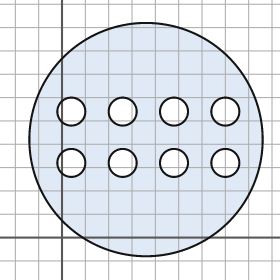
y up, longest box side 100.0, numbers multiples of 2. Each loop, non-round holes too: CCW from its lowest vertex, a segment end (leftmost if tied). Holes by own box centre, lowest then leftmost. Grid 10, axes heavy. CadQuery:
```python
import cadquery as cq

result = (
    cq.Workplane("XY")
    .moveTo(36.0, 42.0)
    .circle(50.0)
    .moveTo(4.0, 32.0)
    .circle(6.0)
    .moveTo(26.0, 32.0)
    .circle(6.0)
    .moveTo(48.0, 32.0)
    .circle(6.0)
    .moveTo(70.0, 32.0)
    .circle(6.0)
    .moveTo(4.0, 54.0)
    .circle(6.0)
    .moveTo(26.0, 54.0)
    .circle(6.0)
    .moveTo(48.0, 54.0)
    .circle(6.0)
    .moveTo(70.0, 54.0)
    .circle(6.0)
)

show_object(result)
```